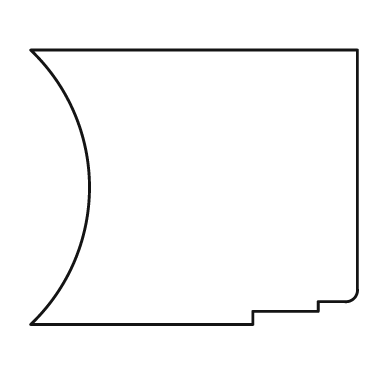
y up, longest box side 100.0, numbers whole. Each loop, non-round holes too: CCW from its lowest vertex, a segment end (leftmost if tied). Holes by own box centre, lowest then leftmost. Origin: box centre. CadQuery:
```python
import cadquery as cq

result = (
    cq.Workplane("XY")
    .moveTo(-50.0, -42.0)
    .lineTo(18.0, -42.0)
    .lineTo(18.0, -38.0)
    .lineTo(38.0, -38.0)
    .lineTo(38.0, -35.0)
    .lineTo(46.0, -35.0)
    .threePointArc((49.0, -34.0), (50.0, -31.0))
    .lineTo(50.0, 42.0)
    .lineTo(-50.0, 42.0)
    .threePointArc((-32.0, 0.0), (-50.0, -42.0))
    .close()
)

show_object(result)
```